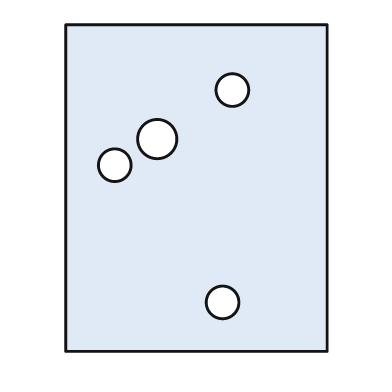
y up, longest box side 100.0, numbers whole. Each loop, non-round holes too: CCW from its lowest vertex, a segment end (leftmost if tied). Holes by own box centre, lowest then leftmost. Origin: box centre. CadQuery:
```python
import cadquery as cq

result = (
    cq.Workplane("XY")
    .moveTo(-40.0, -50.0)
    .lineTo(40.0, -50.0)
    .lineTo(40.0, 50.0)
    .lineTo(-40.0, 50.0)
    .close()
    .moveTo(8.0, -35.0)
    .circle(5.0)
    .moveTo(-25.0, 7.0)
    .circle(5.0)
    .moveTo(-12.0, 15.0)
    .circle(6.0)
    .moveTo(11.0, 30.0)
    .circle(5.0)
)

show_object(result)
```